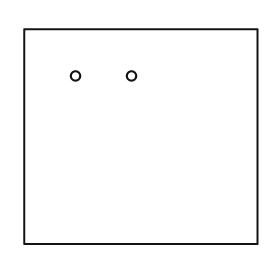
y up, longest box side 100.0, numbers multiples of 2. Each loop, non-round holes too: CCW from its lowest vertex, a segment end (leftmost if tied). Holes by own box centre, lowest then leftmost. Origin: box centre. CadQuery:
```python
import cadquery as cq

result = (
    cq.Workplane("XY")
    .moveTo(-50.0, -46.0)
    .lineTo(50.0, -46.0)
    .lineTo(50.0, 46.0)
    .lineTo(-50.0, 46.0)
    .close()
    .moveTo(-28.0, 26.0)
    .circle(2.0)
    .moveTo(-4.0, 26.0)
    .circle(2.0)
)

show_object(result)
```